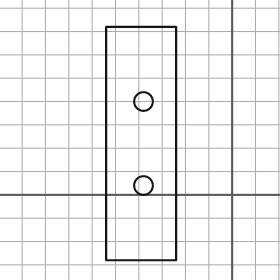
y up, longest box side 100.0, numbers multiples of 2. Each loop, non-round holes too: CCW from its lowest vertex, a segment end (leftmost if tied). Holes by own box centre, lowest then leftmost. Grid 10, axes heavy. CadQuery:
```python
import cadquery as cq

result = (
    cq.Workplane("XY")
    .moveTo(-54.0, -28.0)
    .lineTo(-24.0, -28.0)
    .lineTo(-24.0, 72.0)
    .lineTo(-54.0, 72.0)
    .close()
    .moveTo(-38.0, 4.0)
    .circle(4.0)
    .moveTo(-38.0, 40.0)
    .circle(4.0)
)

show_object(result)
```